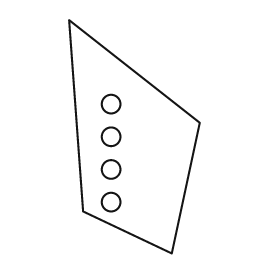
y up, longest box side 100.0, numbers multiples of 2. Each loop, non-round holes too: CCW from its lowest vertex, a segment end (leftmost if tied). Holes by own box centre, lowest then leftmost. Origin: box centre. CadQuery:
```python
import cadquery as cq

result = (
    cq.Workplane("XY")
    .moveTo(16.0, -50.0)
    .lineTo(28.0, 6.0)
    .lineTo(-28.0, 50.0)
    .lineTo(-22.0, -32.0)
    .close()
    .moveTo(-10.0, -28.0)
    .circle(4.0)
    .moveTo(-10.0, -14.0)
    .circle(4.0)
    .moveTo(-10.0, 0.0)
    .circle(4.0)
    .moveTo(-10.0, 14.0)
    .circle(4.0)
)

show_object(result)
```